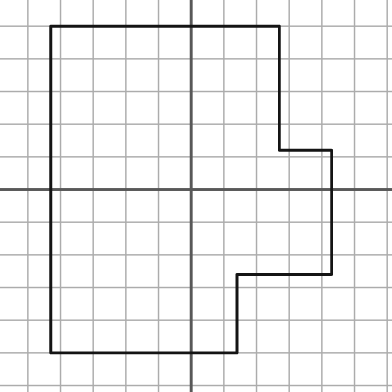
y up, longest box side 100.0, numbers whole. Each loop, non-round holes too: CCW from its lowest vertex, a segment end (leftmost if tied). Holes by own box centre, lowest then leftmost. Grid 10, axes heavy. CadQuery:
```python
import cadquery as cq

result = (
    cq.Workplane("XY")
    .moveTo(-43.0, -50.0)
    .lineTo(14.0, -50.0)
    .lineTo(14.0, -26.0)
    .lineTo(43.0, -26.0)
    .lineTo(43.0, 12.0)
    .lineTo(27.0, 12.0)
    .lineTo(27.0, 50.0)
    .lineTo(-43.0, 50.0)
    .close()
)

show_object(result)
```